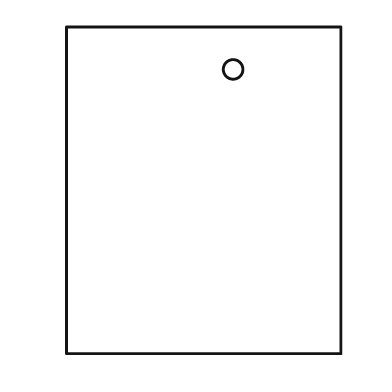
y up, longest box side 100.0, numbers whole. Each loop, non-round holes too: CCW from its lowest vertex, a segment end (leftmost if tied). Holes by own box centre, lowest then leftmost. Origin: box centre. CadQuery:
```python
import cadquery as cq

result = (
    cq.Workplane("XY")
    .moveTo(-42.0, -50.0)
    .lineTo(42.0, -50.0)
    .lineTo(42.0, 50.0)
    .lineTo(-42.0, 50.0)
    .close()
    .moveTo(9.0, 37.0)
    .circle(3.0)
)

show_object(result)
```